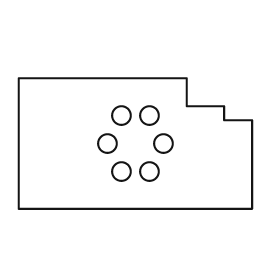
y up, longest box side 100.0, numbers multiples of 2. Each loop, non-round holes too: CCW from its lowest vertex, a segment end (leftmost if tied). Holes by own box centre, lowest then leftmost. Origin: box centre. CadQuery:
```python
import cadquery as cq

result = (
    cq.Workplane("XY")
    .moveTo(-50.0, -28.0)
    .lineTo(50.0, -28.0)
    .lineTo(50.0, 10.0)
    .lineTo(38.0, 10.0)
    .lineTo(38.0, 16.0)
    .lineTo(22.0, 16.0)
    .lineTo(22.0, 28.0)
    .lineTo(-50.0, 28.0)
    .close()
    .moveTo(-6.0, -12.0)
    .circle(4.0)
    .moveTo(6.0, -12.0)
    .circle(4.0)
    .moveTo(-12.0, 0.0)
    .circle(4.0)
    .moveTo(12.0, 0.0)
    .circle(4.0)
    .moveTo(-6.0, 12.0)
    .circle(4.0)
    .moveTo(6.0, 12.0)
    .circle(4.0)
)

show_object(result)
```